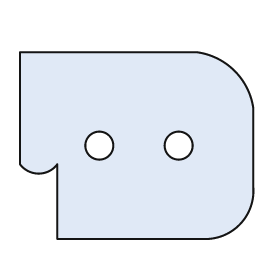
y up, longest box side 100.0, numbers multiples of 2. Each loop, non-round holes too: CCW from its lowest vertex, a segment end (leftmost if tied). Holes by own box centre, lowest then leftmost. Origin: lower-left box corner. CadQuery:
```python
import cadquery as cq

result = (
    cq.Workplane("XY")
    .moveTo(16.0, 0.0)
    .lineTo(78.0, 0.0)
    .threePointArc((94.0, 6.0), (100.0, 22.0))
    .lineTo(100.0, 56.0)
    .threePointArc((92.0, 72.0), (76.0, 80.0))
    .lineTo(0.0, 80.0)
    .lineTo(0.0, 32.0)
    .threePointArc((8.0, 28.0), (16.0, 32.0))
    .close()
    .moveTo(34.0, 40.0)
    .circle(6.0)
    .moveTo(68.0, 40.0)
    .circle(6.0)
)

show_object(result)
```